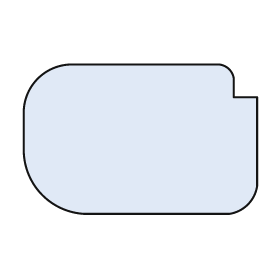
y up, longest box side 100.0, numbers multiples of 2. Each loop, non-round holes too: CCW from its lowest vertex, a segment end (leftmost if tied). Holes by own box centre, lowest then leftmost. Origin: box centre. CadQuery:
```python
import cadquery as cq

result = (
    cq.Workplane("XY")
    .moveTo(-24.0, -32.0)
    .lineTo(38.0, -32.0)
    .threePointArc((46.0, -28.0), (50.0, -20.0))
    .lineTo(50.0, 18.0)
    .lineTo(40.0, 18.0)
    .lineTo(40.0, 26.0)
    .threePointArc((38.0, 30.0), (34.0, 32.0))
    .lineTo(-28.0, 32.0)
    .threePointArc((-44.0, 26.0), (-50.0, 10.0))
    .lineTo(-50.0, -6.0)
    .threePointArc((-42.0, -24.0), (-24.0, -32.0))
    .close()
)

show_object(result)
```